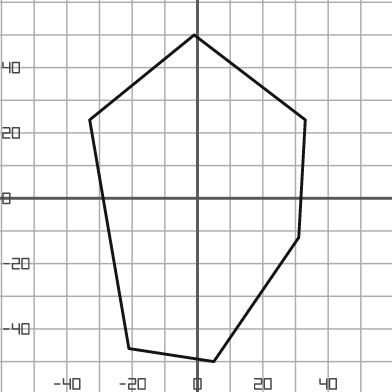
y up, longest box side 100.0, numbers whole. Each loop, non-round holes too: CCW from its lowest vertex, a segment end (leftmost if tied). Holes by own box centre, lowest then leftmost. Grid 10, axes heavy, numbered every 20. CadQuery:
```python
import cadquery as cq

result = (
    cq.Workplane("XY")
    .moveTo(5.0, -50.0)
    .lineTo(31.0, -12.0)
    .lineTo(33.0, 24.0)
    .lineTo(-1.0, 50.0)
    .lineTo(-33.0, 24.0)
    .lineTo(-21.0, -46.0)
    .close()
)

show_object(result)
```